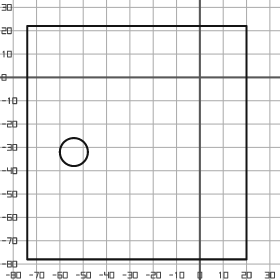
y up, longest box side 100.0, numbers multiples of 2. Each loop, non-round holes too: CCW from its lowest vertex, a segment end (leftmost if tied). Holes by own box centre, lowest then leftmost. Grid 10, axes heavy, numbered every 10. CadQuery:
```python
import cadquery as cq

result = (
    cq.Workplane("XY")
    .moveTo(-74.0, -78.0)
    .lineTo(20.0, -78.0)
    .lineTo(20.0, 22.0)
    .lineTo(-74.0, 22.0)
    .close()
    .moveTo(-54.0, -32.0)
    .circle(6.0)
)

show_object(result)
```